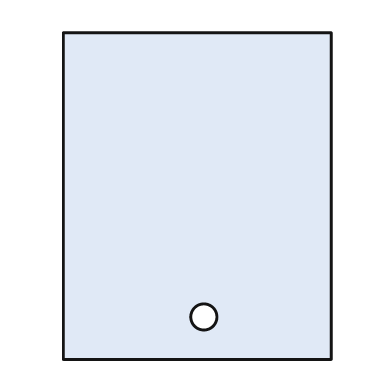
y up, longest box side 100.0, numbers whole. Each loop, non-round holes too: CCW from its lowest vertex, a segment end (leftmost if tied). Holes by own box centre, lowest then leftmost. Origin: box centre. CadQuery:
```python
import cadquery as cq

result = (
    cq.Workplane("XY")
    .moveTo(-41.0, -50.0)
    .lineTo(41.0, -50.0)
    .lineTo(41.0, 50.0)
    .lineTo(-41.0, 50.0)
    .close()
    .moveTo(2.0, -37.0)
    .circle(4.0)
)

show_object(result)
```